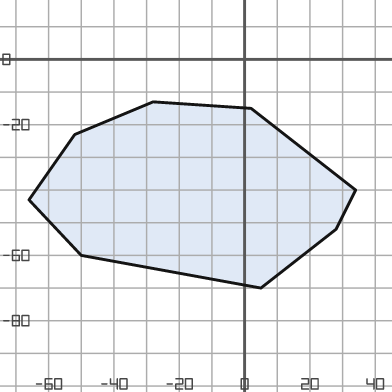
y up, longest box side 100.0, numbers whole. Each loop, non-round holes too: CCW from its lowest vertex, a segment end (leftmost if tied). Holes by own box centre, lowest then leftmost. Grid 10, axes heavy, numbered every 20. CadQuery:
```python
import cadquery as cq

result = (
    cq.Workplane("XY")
    .moveTo(5.0, -70.0)
    .lineTo(28.0, -52.0)
    .lineTo(34.0, -40.0)
    .lineTo(2.0, -15.0)
    .lineTo(-28.0, -13.0)
    .lineTo(-52.0, -23.0)
    .lineTo(-66.0, -43.0)
    .lineTo(-50.0, -60.0)
    .close()
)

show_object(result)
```